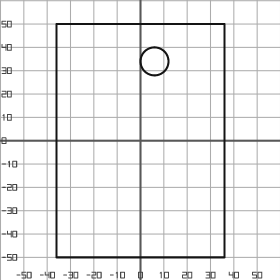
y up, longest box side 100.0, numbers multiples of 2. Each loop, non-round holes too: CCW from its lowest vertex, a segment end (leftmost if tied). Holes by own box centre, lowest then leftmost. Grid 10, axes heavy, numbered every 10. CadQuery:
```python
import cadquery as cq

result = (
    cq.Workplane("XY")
    .moveTo(-36.0, -50.0)
    .lineTo(36.0, -50.0)
    .lineTo(36.0, 50.0)
    .lineTo(-36.0, 50.0)
    .close()
    .moveTo(6.0, 34.0)
    .circle(6.0)
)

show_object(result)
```